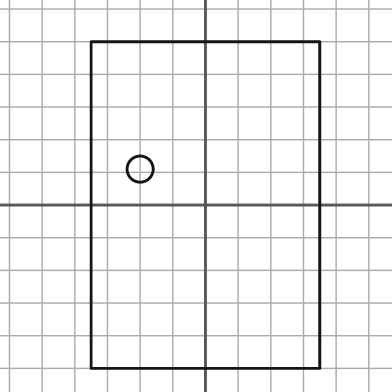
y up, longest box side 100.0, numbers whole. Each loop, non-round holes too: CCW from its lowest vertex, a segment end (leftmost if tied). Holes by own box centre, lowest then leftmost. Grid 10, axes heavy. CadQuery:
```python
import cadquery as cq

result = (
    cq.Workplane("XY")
    .moveTo(-35.0, -50.0)
    .lineTo(35.0, -50.0)
    .lineTo(35.0, 50.0)
    .lineTo(-35.0, 50.0)
    .close()
    .moveTo(-20.0, 11.0)
    .circle(4.0)
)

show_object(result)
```